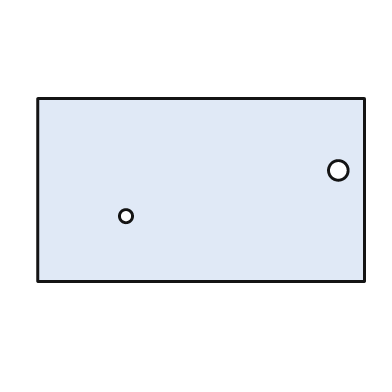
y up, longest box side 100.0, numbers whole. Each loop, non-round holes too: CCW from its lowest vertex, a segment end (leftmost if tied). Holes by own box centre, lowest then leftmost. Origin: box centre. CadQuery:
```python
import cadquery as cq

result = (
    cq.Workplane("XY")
    .moveTo(-50.0, -28.0)
    .lineTo(50.0, -28.0)
    .lineTo(50.0, 28.0)
    .lineTo(-50.0, 28.0)
    .close()
    .moveTo(-23.0, -8.0)
    .circle(2.0)
    .moveTo(42.0, 6.0)
    .circle(3.0)
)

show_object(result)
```